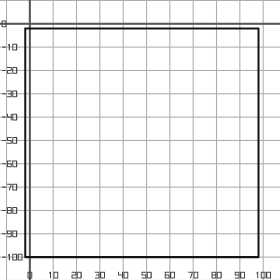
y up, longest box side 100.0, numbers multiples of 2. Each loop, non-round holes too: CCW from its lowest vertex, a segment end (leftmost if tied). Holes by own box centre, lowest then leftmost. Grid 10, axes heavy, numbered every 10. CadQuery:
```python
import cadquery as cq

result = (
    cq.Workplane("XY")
    .moveTo(-2.0, -100.0)
    .lineTo(98.0, -100.0)
    .lineTo(98.0, -2.0)
    .lineTo(-2.0, -2.0)
    .close()
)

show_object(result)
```